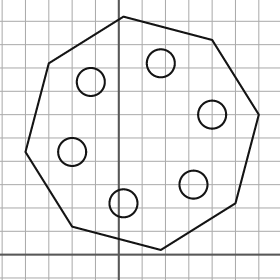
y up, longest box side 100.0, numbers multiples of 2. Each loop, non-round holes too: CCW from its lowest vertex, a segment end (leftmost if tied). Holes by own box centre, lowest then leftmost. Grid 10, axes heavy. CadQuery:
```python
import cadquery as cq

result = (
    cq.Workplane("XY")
    .moveTo(18.0, 2.0)
    .lineTo(50.0, 22.0)
    .lineTo(60.0, 60.0)
    .lineTo(40.0, 92.0)
    .lineTo(2.0, 102.0)
    .lineTo(-30.0, 82.0)
    .lineTo(-40.0, 44.0)
    .lineTo(-20.0, 12.0)
    .close()
    .moveTo(2.0, 22.0)
    .circle(6.0)
    .moveTo(32.0, 30.0)
    .circle(6.0)
    .moveTo(-20.0, 44.0)
    .circle(6.0)
    .moveTo(40.0, 60.0)
    .circle(6.0)
    .moveTo(-12.0, 74.0)
    .circle(6.0)
    .moveTo(18.0, 82.0)
    .circle(6.0)
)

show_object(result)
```